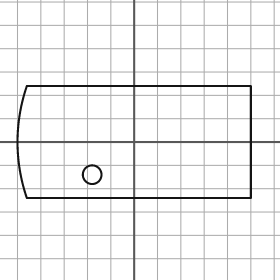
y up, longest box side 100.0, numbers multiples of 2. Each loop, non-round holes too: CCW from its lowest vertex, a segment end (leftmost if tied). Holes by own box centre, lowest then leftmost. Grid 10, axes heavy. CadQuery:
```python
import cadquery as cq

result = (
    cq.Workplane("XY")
    .moveTo(-46.0, -24.0)
    .lineTo(50.0, -24.0)
    .lineTo(50.0, 24.0)
    .lineTo(-46.0, 24.0)
    .threePointArc((-50.0, 0.0), (-46.0, -24.0))
    .close()
    .moveTo(-18.0, -14.0)
    .circle(4.0)
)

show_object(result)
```